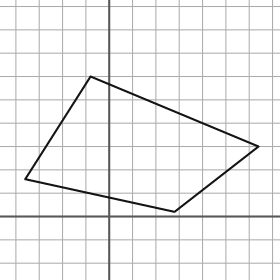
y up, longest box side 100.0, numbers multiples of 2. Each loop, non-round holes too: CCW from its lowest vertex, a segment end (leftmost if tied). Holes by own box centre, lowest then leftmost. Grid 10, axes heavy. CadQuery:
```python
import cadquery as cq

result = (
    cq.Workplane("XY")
    .moveTo(28.0, 2.0)
    .lineTo(64.0, 30.0)
    .lineTo(-8.0, 60.0)
    .lineTo(-36.0, 16.0)
    .close()
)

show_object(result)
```